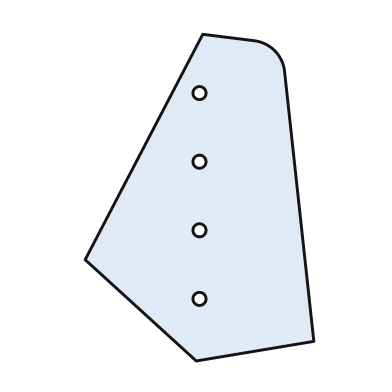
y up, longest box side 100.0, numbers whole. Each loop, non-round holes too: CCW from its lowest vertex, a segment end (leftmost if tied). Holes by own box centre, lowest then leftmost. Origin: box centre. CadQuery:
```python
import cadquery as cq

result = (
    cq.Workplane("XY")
    .moveTo(-1.0, -50.0)
    .lineTo(35.0, -44.0)
    .lineTo(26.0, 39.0)
    .threePointArc((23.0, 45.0), (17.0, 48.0))
    .lineTo(1.0, 50.0)
    .lineTo(-35.0, -19.0)
    .close()
    .moveTo(0.0, -31.0)
    .circle(2.0)
    .moveTo(0.0, -10.0)
    .circle(2.0)
    .moveTo(0.0, 11.0)
    .circle(2.0)
    .moveTo(0.0, 32.0)
    .circle(2.0)
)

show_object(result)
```